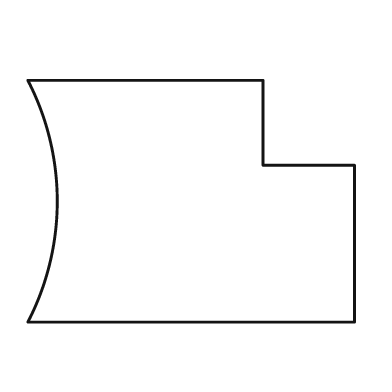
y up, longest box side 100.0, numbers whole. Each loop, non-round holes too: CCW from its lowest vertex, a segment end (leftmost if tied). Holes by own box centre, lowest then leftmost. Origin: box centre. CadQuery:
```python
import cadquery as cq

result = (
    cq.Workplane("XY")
    .moveTo(-50.0, -37.0)
    .lineTo(50.0, -37.0)
    .lineTo(50.0, 11.0)
    .lineTo(22.0, 11.0)
    .lineTo(22.0, 37.0)
    .lineTo(-50.0, 37.0)
    .threePointArc((-41.0, 0.0), (-50.0, -37.0))
    .close()
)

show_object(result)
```